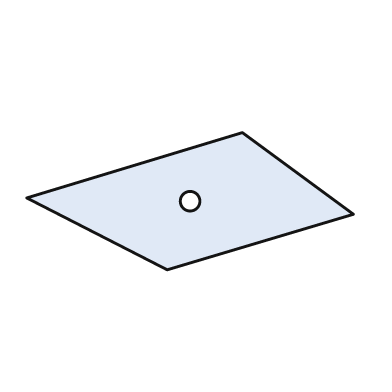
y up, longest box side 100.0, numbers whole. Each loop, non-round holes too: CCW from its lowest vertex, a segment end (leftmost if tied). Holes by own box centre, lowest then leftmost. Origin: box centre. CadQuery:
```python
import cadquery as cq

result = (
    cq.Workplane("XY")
    .moveTo(-7.0, -21.0)
    .lineTo(50.0, -4.0)
    .lineTo(16.0, 21.0)
    .lineTo(-50.0, 1.0)
    .close()
    .moveTo(0.0, 0.0)
    .circle(3.0)
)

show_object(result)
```